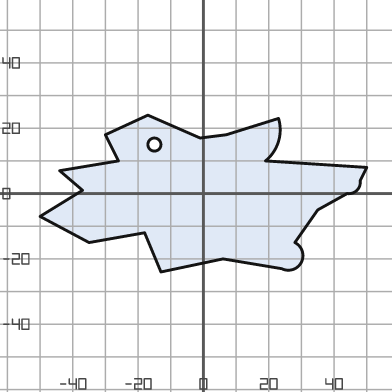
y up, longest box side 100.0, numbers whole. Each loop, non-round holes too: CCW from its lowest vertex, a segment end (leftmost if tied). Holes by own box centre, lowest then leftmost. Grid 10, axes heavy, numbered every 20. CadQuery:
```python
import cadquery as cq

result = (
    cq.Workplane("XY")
    .moveTo(-13.0, -24.0)
    .lineTo(6.0, -20.0)
    .lineTo(24.0, -23.0)
    .threePointArc((30.0, -21.0), (28.0, -15.0))
    .lineTo(35.0, -5.0)
    .lineTo(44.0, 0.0)
    .threePointArc((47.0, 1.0), (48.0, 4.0))
    .lineTo(50.0, 8.0)
    .lineTo(19.0, 10.0)
    .threePointArc((23.0, 16.0), (23.0, 23.0))
    .lineTo(7.0, 18.0)
    .lineTo(-1.0, 17.0)
    .lineTo(-17.0, 24.0)
    .lineTo(-30.0, 18.0)
    .lineTo(-26.0, 10.0)
    .lineTo(-44.0, 7.0)
    .lineTo(-37.0, 1.0)
    .lineTo(-50.0, -7.0)
    .lineTo(-35.0, -15.0)
    .lineTo(-18.0, -12.0)
    .close()
    .moveTo(-15.0, 15.0)
    .circle(2.0)
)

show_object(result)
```